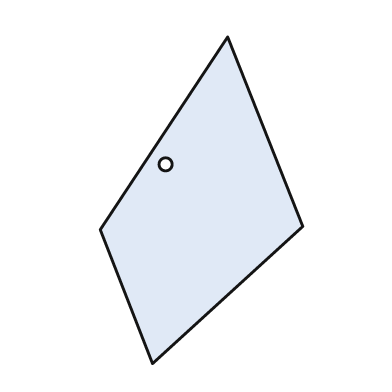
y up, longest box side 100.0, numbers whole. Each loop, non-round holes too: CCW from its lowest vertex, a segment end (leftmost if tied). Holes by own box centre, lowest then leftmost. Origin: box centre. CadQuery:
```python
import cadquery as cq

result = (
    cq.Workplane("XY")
    .moveTo(-15.0, -50.0)
    .lineTo(31.0, -8.0)
    .lineTo(8.0, 50.0)
    .lineTo(-31.0, -9.0)
    .close()
    .moveTo(-11.0, 11.0)
    .circle(2.0)
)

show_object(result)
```